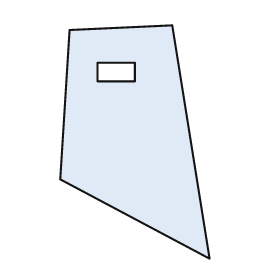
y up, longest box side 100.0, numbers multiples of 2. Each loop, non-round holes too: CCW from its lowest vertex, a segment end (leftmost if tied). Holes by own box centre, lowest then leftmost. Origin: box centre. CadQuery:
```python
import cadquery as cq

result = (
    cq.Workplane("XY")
    .moveTo(32.0, -50.0)
    .lineTo(16.0, 50.0)
    .lineTo(-28.0, 48.0)
    .lineTo(-32.0, -16.0)
    .close()
    .moveTo(-16.0, 26.0)
    .lineTo(0.0, 26.0)
    .lineTo(0.0, 34.0)
    .lineTo(-16.0, 34.0)
    .close()
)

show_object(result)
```